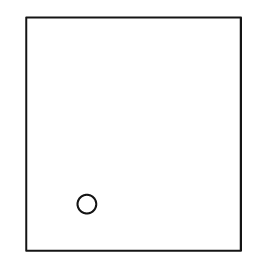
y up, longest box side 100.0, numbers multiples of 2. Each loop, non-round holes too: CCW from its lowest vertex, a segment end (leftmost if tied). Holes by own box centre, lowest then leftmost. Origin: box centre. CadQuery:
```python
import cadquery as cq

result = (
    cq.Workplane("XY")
    .moveTo(-46.0, -50.0)
    .lineTo(46.0, -50.0)
    .lineTo(46.0, 50.0)
    .lineTo(-46.0, 50.0)
    .close()
    .moveTo(-20.0, -30.0)
    .circle(4.0)
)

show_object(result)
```